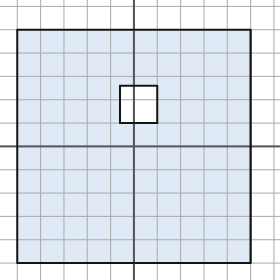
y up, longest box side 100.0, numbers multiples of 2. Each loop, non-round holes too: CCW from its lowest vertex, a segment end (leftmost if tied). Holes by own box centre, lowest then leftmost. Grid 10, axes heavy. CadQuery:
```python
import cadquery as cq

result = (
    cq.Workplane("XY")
    .moveTo(-50.0, -50.0)
    .lineTo(50.0, -50.0)
    .lineTo(50.0, 50.0)
    .lineTo(-50.0, 50.0)
    .close()
    .moveTo(-6.0, 10.0)
    .lineTo(10.0, 10.0)
    .lineTo(10.0, 26.0)
    .lineTo(-6.0, 26.0)
    .close()
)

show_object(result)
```